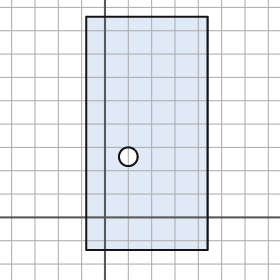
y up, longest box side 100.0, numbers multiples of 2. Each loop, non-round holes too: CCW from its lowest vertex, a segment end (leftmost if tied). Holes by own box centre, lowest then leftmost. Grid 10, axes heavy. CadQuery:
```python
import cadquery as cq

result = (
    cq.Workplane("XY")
    .moveTo(-8.0, -14.0)
    .lineTo(44.0, -14.0)
    .lineTo(44.0, 86.0)
    .lineTo(-8.0, 86.0)
    .close()
    .moveTo(10.0, 26.0)
    .circle(4.0)
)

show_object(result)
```